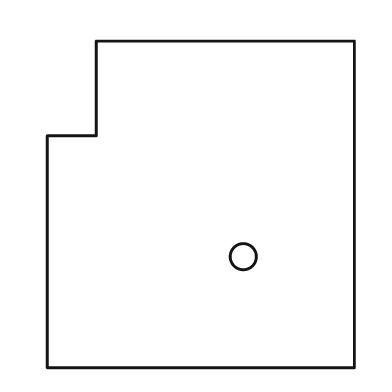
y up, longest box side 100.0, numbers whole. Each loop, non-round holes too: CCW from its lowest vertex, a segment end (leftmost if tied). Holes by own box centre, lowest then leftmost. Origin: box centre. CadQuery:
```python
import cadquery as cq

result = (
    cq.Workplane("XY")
    .moveTo(-47.0, -50.0)
    .lineTo(47.0, -50.0)
    .lineTo(47.0, 50.0)
    .lineTo(-32.0, 50.0)
    .lineTo(-32.0, 21.0)
    .lineTo(-47.0, 21.0)
    .close()
    .moveTo(13.0, -16.0)
    .circle(4.0)
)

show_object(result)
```